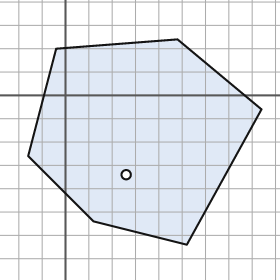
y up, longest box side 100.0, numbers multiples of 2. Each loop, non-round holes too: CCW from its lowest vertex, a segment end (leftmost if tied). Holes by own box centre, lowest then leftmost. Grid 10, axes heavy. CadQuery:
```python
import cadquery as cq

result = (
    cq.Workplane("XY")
    .moveTo(52.0, -64.0)
    .lineTo(84.0, -6.0)
    .lineTo(48.0, 24.0)
    .lineTo(-4.0, 20.0)
    .lineTo(-16.0, -26.0)
    .lineTo(12.0, -54.0)
    .close()
    .moveTo(26.0, -34.0)
    .circle(2.0)
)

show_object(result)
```